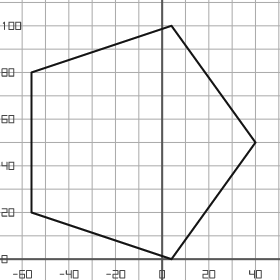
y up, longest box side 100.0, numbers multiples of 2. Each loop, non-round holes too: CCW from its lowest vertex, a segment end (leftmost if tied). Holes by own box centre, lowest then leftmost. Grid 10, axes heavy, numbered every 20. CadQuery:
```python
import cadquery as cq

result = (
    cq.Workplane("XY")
    .moveTo(4.0, 0.0)
    .lineTo(40.0, 50.0)
    .lineTo(4.0, 100.0)
    .lineTo(-56.0, 80.0)
    .lineTo(-56.0, 20.0)
    .close()
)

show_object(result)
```